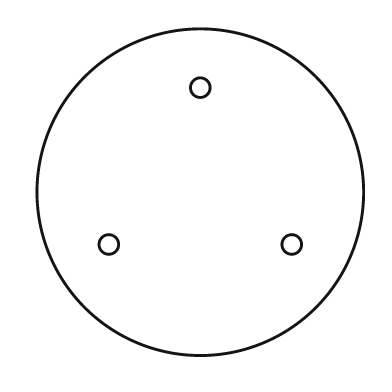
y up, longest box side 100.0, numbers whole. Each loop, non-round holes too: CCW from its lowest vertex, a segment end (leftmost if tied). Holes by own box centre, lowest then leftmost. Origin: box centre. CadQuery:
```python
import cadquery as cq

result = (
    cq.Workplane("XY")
    .moveTo(0.0, 0.0)
    .circle(50.0)
    .moveTo(-28.0, -16.0)
    .circle(3.0)
    .moveTo(28.0, -16.0)
    .circle(3.0)
    .moveTo(0.0, 32.0)
    .circle(3.0)
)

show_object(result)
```